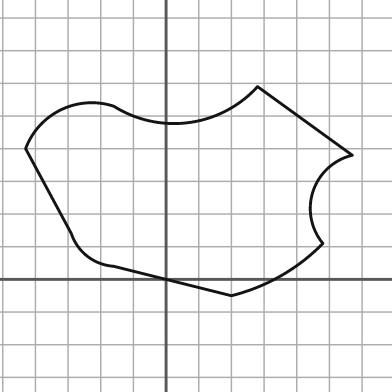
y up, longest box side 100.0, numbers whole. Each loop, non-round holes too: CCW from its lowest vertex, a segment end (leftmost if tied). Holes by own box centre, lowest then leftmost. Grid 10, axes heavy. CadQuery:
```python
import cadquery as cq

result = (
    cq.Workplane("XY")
    .moveTo(20.0, -5.0)
    .threePointArc((35.0, 1.0), (48.0, 11.0))
    .threePointArc((45.0, 27.0), (57.0, 38.0))
    .lineTo(28.0, 59.0)
    .threePointArc((7.0, 48.0), (-16.0, 53.0))
    .threePointArc((-32.0, 52.0), (-43.0, 40.0))
    .lineTo(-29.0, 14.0)
    .threePointArc((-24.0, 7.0), (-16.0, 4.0))
    .close()
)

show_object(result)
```